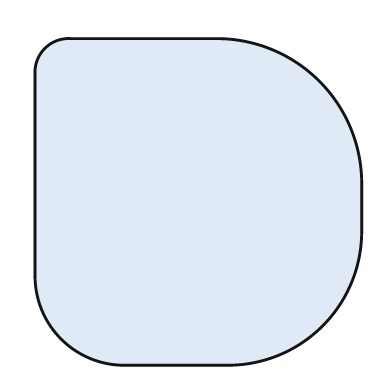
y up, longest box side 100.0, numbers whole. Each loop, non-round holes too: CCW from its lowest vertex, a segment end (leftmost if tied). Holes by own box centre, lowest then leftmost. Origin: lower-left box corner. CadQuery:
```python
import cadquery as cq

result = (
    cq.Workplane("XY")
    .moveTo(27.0, 0.0)
    .lineTo(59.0, 0.0)
    .threePointArc((88.0, 12.0), (100.0, 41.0))
    .lineTo(100.0, 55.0)
    .threePointArc((87.0, 87.0), (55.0, 100.0))
    .lineTo(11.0, 100.0)
    .threePointArc((3.0, 97.0), (0.0, 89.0))
    .lineTo(0.0, 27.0)
    .threePointArc((8.0, 8.0), (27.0, 0.0))
    .close()
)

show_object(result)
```